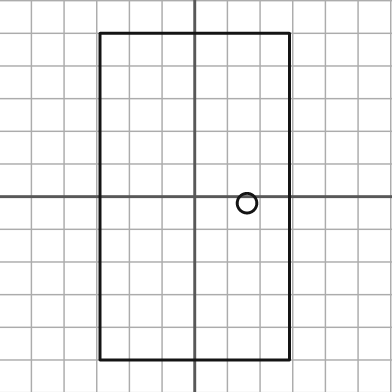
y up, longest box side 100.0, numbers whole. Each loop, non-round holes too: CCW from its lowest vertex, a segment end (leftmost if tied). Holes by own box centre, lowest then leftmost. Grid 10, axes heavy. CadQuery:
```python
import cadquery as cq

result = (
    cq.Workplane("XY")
    .moveTo(-29.0, -50.0)
    .lineTo(29.0, -50.0)
    .lineTo(29.0, 50.0)
    .lineTo(-29.0, 50.0)
    .close()
    .moveTo(16.0, -2.0)
    .circle(3.0)
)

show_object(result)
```